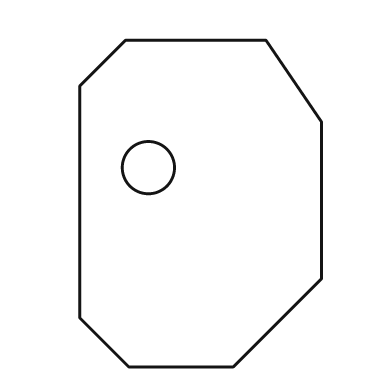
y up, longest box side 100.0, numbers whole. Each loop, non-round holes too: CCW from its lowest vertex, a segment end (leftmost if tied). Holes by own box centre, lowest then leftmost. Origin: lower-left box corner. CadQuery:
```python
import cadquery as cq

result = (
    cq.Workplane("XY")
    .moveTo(15.0, 0.0)
    .lineTo(47.0, 0.0)
    .lineTo(74.0, 27.0)
    .lineTo(74.0, 75.0)
    .lineTo(57.0, 100.0)
    .lineTo(14.0, 100.0)
    .lineTo(0.0, 86.0)
    .lineTo(0.0, 15.0)
    .close()
    .moveTo(21.0, 61.0)
    .circle(8.0)
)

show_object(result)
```